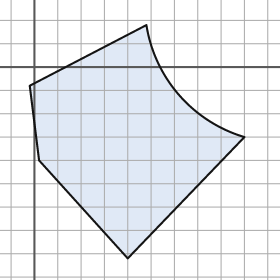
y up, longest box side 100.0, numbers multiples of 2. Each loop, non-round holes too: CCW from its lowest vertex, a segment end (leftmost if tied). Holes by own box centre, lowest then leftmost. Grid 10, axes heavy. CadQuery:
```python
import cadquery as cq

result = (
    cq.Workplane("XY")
    .moveTo(40.0, -82.0)
    .lineTo(90.0, -30.0)
    .threePointArc((62.0, -12.0), (48.0, 18.0))
    .lineTo(-2.0, -8.0)
    .lineTo(2.0, -40.0)
    .close()
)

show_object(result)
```